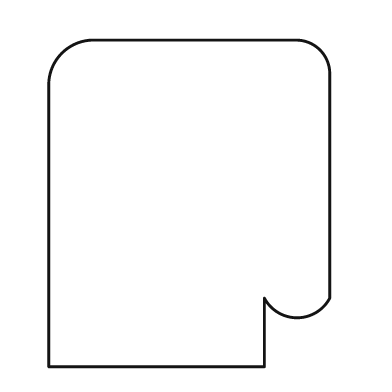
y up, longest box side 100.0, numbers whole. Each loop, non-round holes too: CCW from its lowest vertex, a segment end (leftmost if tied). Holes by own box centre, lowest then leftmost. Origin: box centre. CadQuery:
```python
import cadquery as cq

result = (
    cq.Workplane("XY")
    .moveTo(-43.0, -50.0)
    .lineTo(23.0, -50.0)
    .lineTo(23.0, -29.0)
    .threePointArc((33.0, -35.0), (43.0, -29.0))
    .lineTo(43.0, 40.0)
    .threePointArc((40.0, 47.0), (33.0, 50.0))
    .lineTo(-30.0, 50.0)
    .threePointArc((-39.0, 46.0), (-43.0, 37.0))
    .close()
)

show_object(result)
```